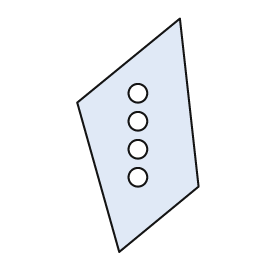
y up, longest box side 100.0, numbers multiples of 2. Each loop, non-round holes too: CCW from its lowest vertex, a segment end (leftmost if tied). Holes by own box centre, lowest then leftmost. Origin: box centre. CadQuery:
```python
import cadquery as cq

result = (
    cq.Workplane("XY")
    .moveTo(-8.0, -50.0)
    .lineTo(26.0, -22.0)
    .lineTo(18.0, 50.0)
    .lineTo(-26.0, 14.0)
    .close()
    .moveTo(0.0, -18.0)
    .circle(4.0)
    .moveTo(0.0, -6.0)
    .circle(4.0)
    .moveTo(0.0, 6.0)
    .circle(4.0)
    .moveTo(0.0, 18.0)
    .circle(4.0)
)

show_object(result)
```